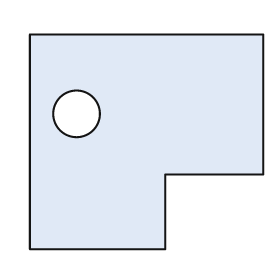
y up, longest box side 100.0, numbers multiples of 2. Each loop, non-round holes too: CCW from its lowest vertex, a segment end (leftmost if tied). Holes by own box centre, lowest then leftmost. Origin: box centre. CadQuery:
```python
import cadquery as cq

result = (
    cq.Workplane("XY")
    .moveTo(-50.0, -46.0)
    .lineTo(8.0, -46.0)
    .lineTo(8.0, -14.0)
    .lineTo(50.0, -14.0)
    .lineTo(50.0, 46.0)
    .lineTo(-50.0, 46.0)
    .close()
    .moveTo(-30.0, 12.0)
    .circle(10.0)
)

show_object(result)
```